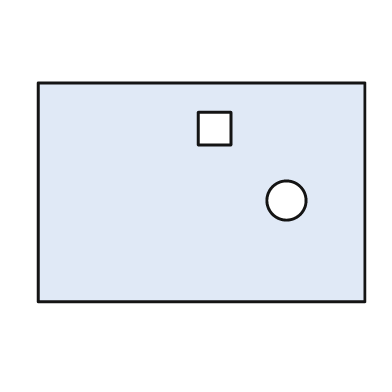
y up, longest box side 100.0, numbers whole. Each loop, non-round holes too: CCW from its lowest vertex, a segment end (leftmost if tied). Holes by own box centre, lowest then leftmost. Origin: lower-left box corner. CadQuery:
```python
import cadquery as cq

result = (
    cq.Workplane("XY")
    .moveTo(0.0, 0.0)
    .lineTo(100.0, 0.0)
    .lineTo(100.0, 67.0)
    .lineTo(0.0, 67.0)
    .close()
    .moveTo(76.0, 31.0)
    .circle(6.0)
    .moveTo(49.0, 48.0)
    .lineTo(59.0, 48.0)
    .lineTo(59.0, 58.0)
    .lineTo(49.0, 58.0)
    .close()
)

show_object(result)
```